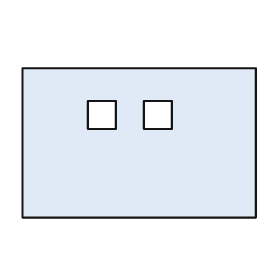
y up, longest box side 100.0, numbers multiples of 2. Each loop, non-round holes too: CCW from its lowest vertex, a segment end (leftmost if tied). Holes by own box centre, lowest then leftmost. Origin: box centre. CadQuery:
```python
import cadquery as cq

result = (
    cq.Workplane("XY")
    .moveTo(-50.0, -32.0)
    .lineTo(50.0, -32.0)
    .lineTo(50.0, 32.0)
    .lineTo(-50.0, 32.0)
    .close()
    .moveTo(-22.0, 6.0)
    .lineTo(-10.0, 6.0)
    .lineTo(-10.0, 18.0)
    .lineTo(-22.0, 18.0)
    .close()
    .moveTo(2.0, 6.0)
    .lineTo(14.0, 6.0)
    .lineTo(14.0, 18.0)
    .lineTo(2.0, 18.0)
    .close()
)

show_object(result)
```